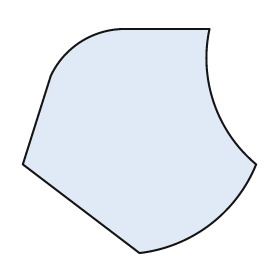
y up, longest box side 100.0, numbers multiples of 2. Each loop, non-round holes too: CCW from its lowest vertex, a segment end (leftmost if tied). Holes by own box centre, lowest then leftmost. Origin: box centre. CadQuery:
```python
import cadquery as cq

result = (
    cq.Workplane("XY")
    .moveTo(0.0, -48.0)
    .threePointArc((30.0, -36.0), (50.0, -10.0))
    .threePointArc((32.0, 16.0), (30.0, 48.0))
    .lineTo(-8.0, 48.0)
    .threePointArc((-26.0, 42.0), (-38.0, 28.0))
    .lineTo(-50.0, -10.0)
    .close()
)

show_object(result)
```